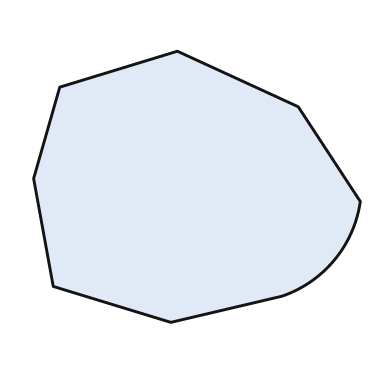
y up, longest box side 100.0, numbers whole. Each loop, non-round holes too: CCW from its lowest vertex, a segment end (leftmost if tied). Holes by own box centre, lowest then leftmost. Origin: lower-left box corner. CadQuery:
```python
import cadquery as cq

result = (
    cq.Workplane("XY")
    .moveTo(42.0, 0.0)
    .lineTo(76.0, 8.0)
    .threePointArc((92.0, 19.0), (100.0, 37.0))
    .lineTo(81.0, 66.0)
    .lineTo(44.0, 83.0)
    .lineTo(8.0, 72.0)
    .lineTo(0.0, 44.0)
    .lineTo(6.0, 11.0)
    .close()
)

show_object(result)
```